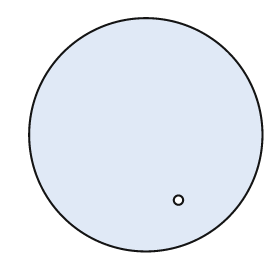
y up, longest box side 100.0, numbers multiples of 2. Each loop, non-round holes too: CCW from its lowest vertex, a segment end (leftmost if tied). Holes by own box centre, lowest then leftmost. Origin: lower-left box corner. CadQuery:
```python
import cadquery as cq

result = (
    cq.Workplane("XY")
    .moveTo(50.0, 50.0)
    .circle(50.0)
    .moveTo(64.0, 22.0)
    .circle(2.0)
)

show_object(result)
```